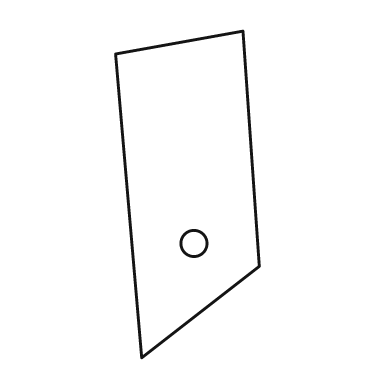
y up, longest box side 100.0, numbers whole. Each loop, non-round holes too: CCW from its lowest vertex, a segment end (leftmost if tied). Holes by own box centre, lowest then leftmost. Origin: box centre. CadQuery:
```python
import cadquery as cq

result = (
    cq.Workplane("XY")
    .moveTo(-14.0, -50.0)
    .lineTo(22.0, -22.0)
    .lineTo(17.0, 50.0)
    .lineTo(-22.0, 43.0)
    .close()
    .moveTo(2.0, -15.0)
    .circle(4.0)
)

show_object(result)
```